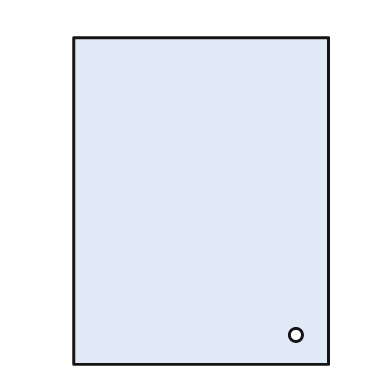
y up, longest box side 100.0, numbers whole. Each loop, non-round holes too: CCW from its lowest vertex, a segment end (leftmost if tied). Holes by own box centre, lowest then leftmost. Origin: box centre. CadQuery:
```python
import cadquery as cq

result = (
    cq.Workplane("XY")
    .moveTo(-39.0, -50.0)
    .lineTo(39.0, -50.0)
    .lineTo(39.0, 50.0)
    .lineTo(-39.0, 50.0)
    .close()
    .moveTo(29.0, -41.0)
    .circle(2.0)
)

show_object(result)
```